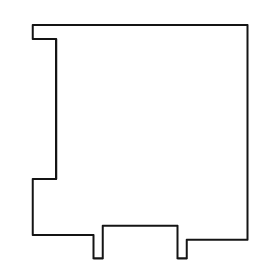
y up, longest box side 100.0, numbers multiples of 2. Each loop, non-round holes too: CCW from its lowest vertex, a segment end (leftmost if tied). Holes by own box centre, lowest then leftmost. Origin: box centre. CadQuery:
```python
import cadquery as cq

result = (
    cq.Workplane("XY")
    .moveTo(-20.0, -50.0)
    .lineTo(-16.0, -50.0)
    .lineTo(-16.0, -36.0)
    .lineTo(16.0, -36.0)
    .lineTo(16.0, -50.0)
    .lineTo(20.0, -50.0)
    .lineTo(20.0, -42.0)
    .lineTo(46.0, -42.0)
    .lineTo(46.0, 50.0)
    .lineTo(-46.0, 50.0)
    .lineTo(-46.0, 44.0)
    .lineTo(-36.0, 44.0)
    .lineTo(-36.0, -16.0)
    .lineTo(-46.0, -16.0)
    .lineTo(-46.0, -40.0)
    .lineTo(-20.0, -40.0)
    .close()
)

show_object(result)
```